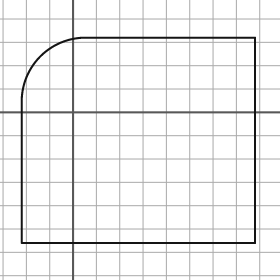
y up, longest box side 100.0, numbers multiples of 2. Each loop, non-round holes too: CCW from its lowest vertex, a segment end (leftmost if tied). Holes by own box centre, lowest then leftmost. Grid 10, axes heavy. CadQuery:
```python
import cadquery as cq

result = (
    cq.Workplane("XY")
    .moveTo(-22.0, -56.0)
    .lineTo(78.0, -56.0)
    .lineTo(78.0, 32.0)
    .lineTo(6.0, 32.0)
    .threePointArc((-14.0, 24.0), (-22.0, 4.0))
    .close()
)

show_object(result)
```